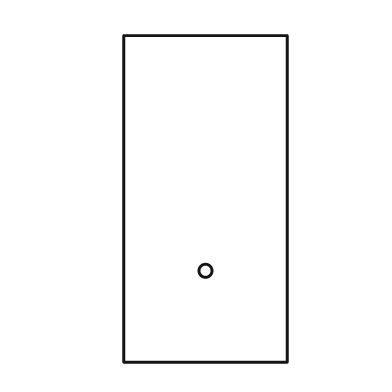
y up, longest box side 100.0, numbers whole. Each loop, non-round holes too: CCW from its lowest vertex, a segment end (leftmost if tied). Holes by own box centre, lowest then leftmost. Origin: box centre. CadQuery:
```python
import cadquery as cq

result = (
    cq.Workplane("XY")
    .moveTo(-25.0, -50.0)
    .lineTo(25.0, -50.0)
    .lineTo(25.0, 50.0)
    .lineTo(-25.0, 50.0)
    .close()
    .moveTo(0.0, -22.0)
    .circle(2.0)
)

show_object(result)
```